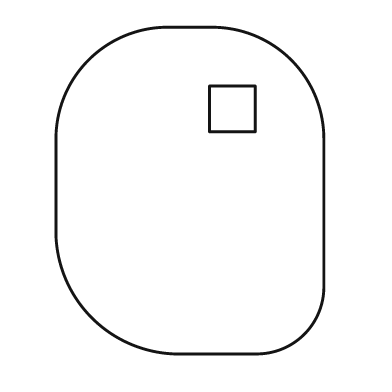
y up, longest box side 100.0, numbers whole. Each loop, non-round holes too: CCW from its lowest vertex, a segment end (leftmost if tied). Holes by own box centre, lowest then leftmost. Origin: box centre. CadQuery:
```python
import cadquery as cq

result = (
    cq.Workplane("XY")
    .moveTo(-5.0, -50.0)
    .lineTo(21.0, -50.0)
    .threePointArc((35.0, -44.0), (41.0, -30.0))
    .lineTo(41.0, 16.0)
    .threePointArc((31.0, 40.0), (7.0, 50.0))
    .lineTo(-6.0, 50.0)
    .threePointArc((-31.0, 40.0), (-41.0, 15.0))
    .lineTo(-41.0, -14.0)
    .threePointArc((-30.0, -39.0), (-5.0, -50.0))
    .close()
    .moveTo(6.0, 18.0)
    .lineTo(20.0, 18.0)
    .lineTo(20.0, 32.0)
    .lineTo(6.0, 32.0)
    .close()
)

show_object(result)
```